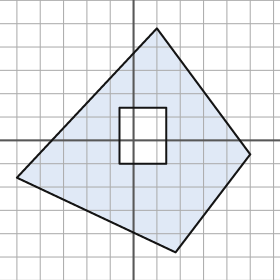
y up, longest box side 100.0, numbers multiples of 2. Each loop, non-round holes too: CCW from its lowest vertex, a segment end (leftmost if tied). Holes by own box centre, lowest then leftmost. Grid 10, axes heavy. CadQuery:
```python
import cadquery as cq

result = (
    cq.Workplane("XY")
    .moveTo(18.0, -48.0)
    .lineTo(50.0, -6.0)
    .lineTo(10.0, 48.0)
    .lineTo(-50.0, -16.0)
    .close()
    .moveTo(-6.0, -10.0)
    .lineTo(14.0, -10.0)
    .lineTo(14.0, 14.0)
    .lineTo(-6.0, 14.0)
    .close()
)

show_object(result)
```